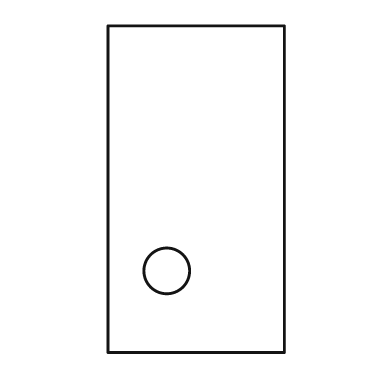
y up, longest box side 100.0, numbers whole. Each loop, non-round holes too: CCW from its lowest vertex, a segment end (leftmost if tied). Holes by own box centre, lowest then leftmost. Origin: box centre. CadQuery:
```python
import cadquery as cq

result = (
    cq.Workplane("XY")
    .moveTo(-27.0, -50.0)
    .lineTo(27.0, -50.0)
    .lineTo(27.0, 50.0)
    .lineTo(-27.0, 50.0)
    .close()
    .moveTo(-9.0, -25.0)
    .circle(7.0)
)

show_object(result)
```